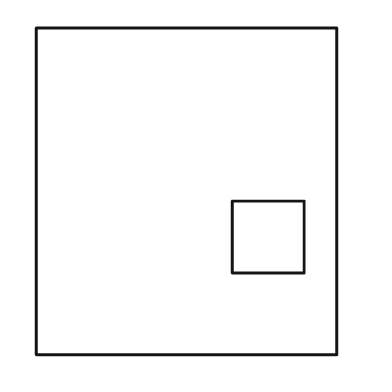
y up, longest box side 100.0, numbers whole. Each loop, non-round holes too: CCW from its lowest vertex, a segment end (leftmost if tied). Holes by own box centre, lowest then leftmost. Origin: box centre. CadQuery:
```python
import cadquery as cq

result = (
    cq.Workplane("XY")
    .moveTo(-46.0, -50.0)
    .lineTo(46.0, -50.0)
    .lineTo(46.0, 50.0)
    .lineTo(-46.0, 50.0)
    .close()
    .moveTo(14.0, -25.0)
    .lineTo(36.0, -25.0)
    .lineTo(36.0, -3.0)
    .lineTo(14.0, -3.0)
    .close()
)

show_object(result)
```